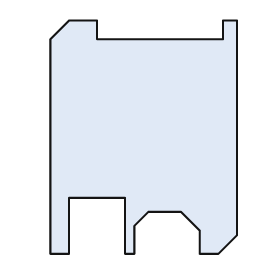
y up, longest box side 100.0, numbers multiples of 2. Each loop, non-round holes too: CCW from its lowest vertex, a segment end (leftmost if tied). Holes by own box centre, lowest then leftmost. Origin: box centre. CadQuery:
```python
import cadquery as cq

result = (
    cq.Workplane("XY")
    .moveTo(-40.0, -50.0)
    .lineTo(-32.0, -50.0)
    .lineTo(-32.0, -26.0)
    .lineTo(-8.0, -26.0)
    .lineTo(-8.0, -50.0)
    .lineTo(-4.0, -50.0)
    .lineTo(-4.0, -38.0)
    .lineTo(2.0, -32.0)
    .lineTo(16.0, -32.0)
    .lineTo(24.0, -40.0)
    .lineTo(24.0, -50.0)
    .lineTo(32.0, -50.0)
    .lineTo(40.0, -42.0)
    .lineTo(40.0, 50.0)
    .lineTo(34.0, 50.0)
    .lineTo(34.0, 42.0)
    .lineTo(-20.0, 42.0)
    .lineTo(-20.0, 50.0)
    .lineTo(-32.0, 50.0)
    .lineTo(-40.0, 42.0)
    .close()
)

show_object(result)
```